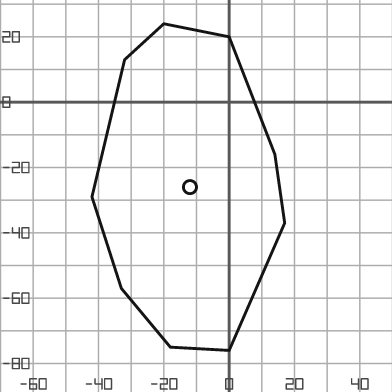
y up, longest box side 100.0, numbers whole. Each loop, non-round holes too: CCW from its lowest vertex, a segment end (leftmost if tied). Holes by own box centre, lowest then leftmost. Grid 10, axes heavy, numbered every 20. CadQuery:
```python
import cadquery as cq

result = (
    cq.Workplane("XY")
    .moveTo(0.0, -76.0)
    .lineTo(17.0, -37.0)
    .lineTo(14.0, -16.0)
    .lineTo(0.0, 20.0)
    .lineTo(-20.0, 24.0)
    .lineTo(-32.0, 13.0)
    .lineTo(-42.0, -29.0)
    .lineTo(-33.0, -57.0)
    .lineTo(-18.0, -75.0)
    .close()
    .moveTo(-12.0, -26.0)
    .circle(2.0)
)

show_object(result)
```